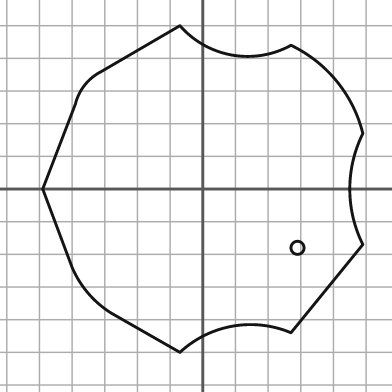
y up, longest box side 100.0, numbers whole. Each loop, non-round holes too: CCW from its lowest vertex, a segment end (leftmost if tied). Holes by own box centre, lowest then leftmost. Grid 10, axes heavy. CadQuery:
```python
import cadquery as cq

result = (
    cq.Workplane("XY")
    .moveTo(-7.0, -50.0)
    .threePointArc((9.0, -42.0), (27.0, -44.0))
    .lineTo(49.0, -17.0)
    .threePointArc((45.0, 0.0), (49.0, 17.0))
    .threePointArc((41.0, 33.0), (27.0, 44.0))
    .threePointArc((9.0, 41.0), (-7.0, 50.0))
    .lineTo(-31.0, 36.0)
    .threePointArc((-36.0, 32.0), (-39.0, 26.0))
    .lineTo(-49.0, 0.0)
    .lineTo(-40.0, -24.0)
    .threePointArc((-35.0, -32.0), (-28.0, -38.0))
    .close()
    .moveTo(29.0, -18.0)
    .circle(2.0)
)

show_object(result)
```